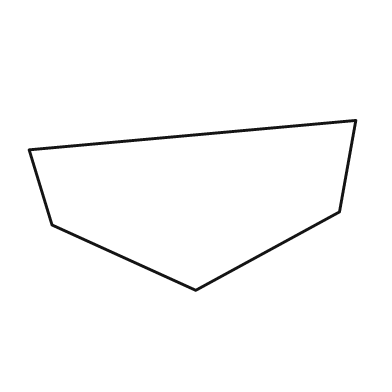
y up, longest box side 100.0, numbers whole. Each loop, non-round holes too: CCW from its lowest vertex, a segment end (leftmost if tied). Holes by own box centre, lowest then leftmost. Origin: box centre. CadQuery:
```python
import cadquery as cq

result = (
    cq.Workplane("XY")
    .moveTo(1.0, -26.0)
    .lineTo(45.0, -2.0)
    .lineTo(50.0, 26.0)
    .lineTo(-50.0, 17.0)
    .lineTo(-43.0, -6.0)
    .close()
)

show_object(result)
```